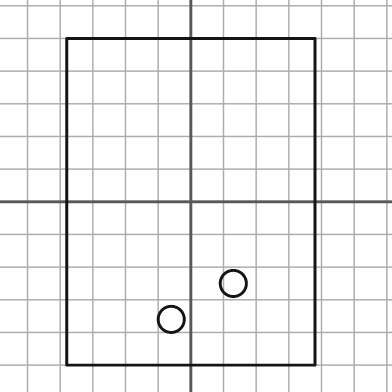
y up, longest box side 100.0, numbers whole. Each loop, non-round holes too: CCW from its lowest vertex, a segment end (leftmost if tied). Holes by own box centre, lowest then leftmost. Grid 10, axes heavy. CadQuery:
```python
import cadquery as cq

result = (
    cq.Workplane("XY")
    .moveTo(-38.0, -50.0)
    .lineTo(38.0, -50.0)
    .lineTo(38.0, 50.0)
    .lineTo(-38.0, 50.0)
    .close()
    .moveTo(-6.0, -36.0)
    .circle(4.0)
    .moveTo(13.0, -25.0)
    .circle(4.0)
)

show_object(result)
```